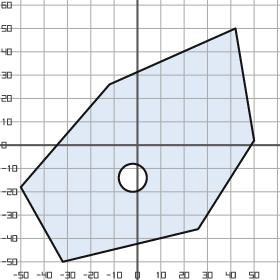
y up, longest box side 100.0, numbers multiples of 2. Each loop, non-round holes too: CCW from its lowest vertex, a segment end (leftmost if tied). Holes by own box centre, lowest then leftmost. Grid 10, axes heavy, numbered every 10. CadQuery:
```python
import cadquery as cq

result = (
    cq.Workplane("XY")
    .moveTo(-32.0, -50.0)
    .lineTo(26.0, -36.0)
    .lineTo(50.0, 2.0)
    .lineTo(42.0, 50.0)
    .lineTo(-12.0, 26.0)
    .lineTo(-50.0, -18.0)
    .close()
    .moveTo(-2.0, -14.0)
    .circle(6.0)
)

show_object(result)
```